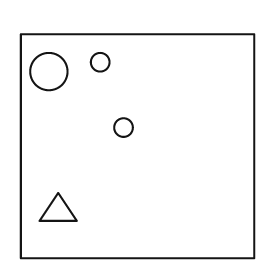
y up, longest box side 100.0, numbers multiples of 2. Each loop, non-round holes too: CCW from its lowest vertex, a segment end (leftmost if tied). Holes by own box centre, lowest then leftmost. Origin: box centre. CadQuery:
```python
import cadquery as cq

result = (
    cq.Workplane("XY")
    .moveTo(-50.0, -48.0)
    .lineTo(50.0, -48.0)
    .lineTo(50.0, 48.0)
    .lineTo(-50.0, 48.0)
    .close()
    .moveTo(-42.0, -32.0)
    .lineTo(-26.0, -32.0)
    .lineTo(-34.0, -20.0)
    .close()
    .moveTo(-6.0, 8.0)
    .circle(4.0)
    .moveTo(-38.0, 32.0)
    .circle(8.0)
    .moveTo(-16.0, 36.0)
    .circle(4.0)
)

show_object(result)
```